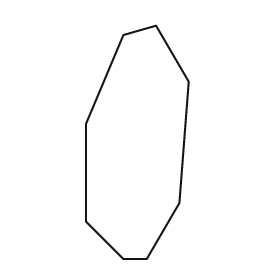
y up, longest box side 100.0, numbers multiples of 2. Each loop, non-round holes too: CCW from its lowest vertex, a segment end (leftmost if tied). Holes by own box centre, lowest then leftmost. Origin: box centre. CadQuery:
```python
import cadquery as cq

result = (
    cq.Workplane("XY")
    .moveTo(-6.0, -50.0)
    .lineTo(4.0, -50.0)
    .lineTo(18.0, -26.0)
    .lineTo(22.0, 26.0)
    .lineTo(8.0, 50.0)
    .lineTo(-6.0, 46.0)
    .lineTo(-22.0, 8.0)
    .lineTo(-22.0, -34.0)
    .close()
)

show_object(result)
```